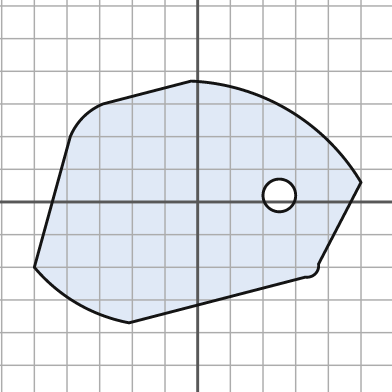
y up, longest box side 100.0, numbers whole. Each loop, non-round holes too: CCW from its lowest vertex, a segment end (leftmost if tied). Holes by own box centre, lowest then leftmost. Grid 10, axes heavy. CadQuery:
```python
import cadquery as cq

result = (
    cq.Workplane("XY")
    .moveTo(-21.0, -37.0)
    .lineTo(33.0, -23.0)
    .threePointArc((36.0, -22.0), (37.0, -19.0))
    .lineTo(50.0, 6.0)
    .threePointArc((28.0, 28.0), (-2.0, 37.0))
    .lineTo(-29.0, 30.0)
    .threePointArc((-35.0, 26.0), (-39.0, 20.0))
    .lineTo(-50.0, -20.0)
    .threePointArc((-37.0, -31.0), (-21.0, -37.0))
    .close()
    .moveTo(25.0, 2.0)
    .circle(5.0)
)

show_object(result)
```